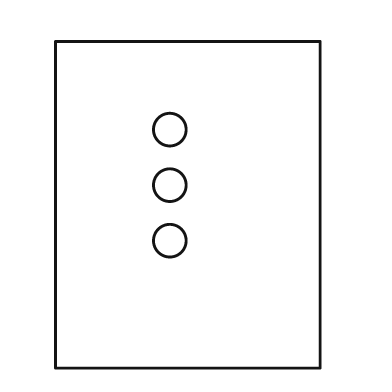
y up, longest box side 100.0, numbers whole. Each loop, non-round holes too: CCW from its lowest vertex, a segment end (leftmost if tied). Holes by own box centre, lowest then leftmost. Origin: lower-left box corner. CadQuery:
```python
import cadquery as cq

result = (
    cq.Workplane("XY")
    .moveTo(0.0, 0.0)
    .lineTo(81.0, 0.0)
    .lineTo(81.0, 100.0)
    .lineTo(0.0, 100.0)
    .close()
    .moveTo(35.0, 39.0)
    .circle(5.0)
    .moveTo(35.0, 56.0)
    .circle(5.0)
    .moveTo(35.0, 73.0)
    .circle(5.0)
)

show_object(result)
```